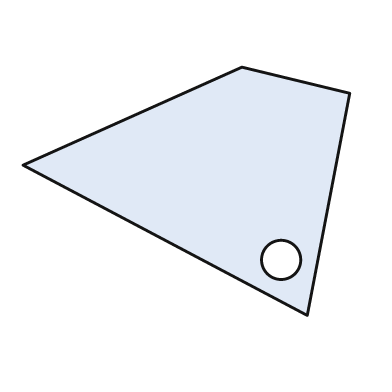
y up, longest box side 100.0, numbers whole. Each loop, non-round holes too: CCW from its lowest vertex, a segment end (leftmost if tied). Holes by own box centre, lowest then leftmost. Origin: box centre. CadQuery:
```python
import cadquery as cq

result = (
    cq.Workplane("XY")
    .moveTo(37.0, -38.0)
    .lineTo(50.0, 30.0)
    .lineTo(17.0, 38.0)
    .lineTo(-50.0, 8.0)
    .close()
    .moveTo(29.0, -21.0)
    .circle(6.0)
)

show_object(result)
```